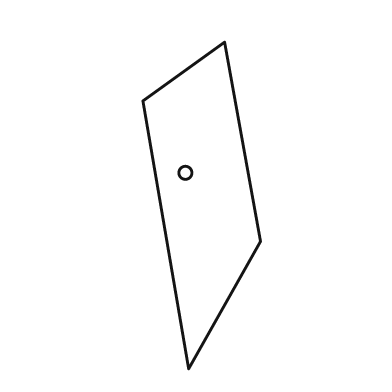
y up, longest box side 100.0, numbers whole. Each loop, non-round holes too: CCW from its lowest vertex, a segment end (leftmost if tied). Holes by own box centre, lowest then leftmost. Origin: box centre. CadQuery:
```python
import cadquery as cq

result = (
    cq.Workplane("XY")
    .moveTo(-4.0, -50.0)
    .lineTo(18.0, -11.0)
    .lineTo(7.0, 50.0)
    .lineTo(-18.0, 32.0)
    .close()
    .moveTo(-5.0, 10.0)
    .circle(2.0)
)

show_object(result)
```